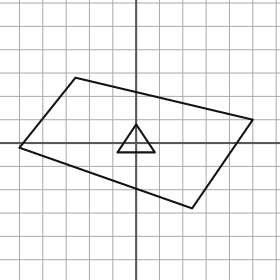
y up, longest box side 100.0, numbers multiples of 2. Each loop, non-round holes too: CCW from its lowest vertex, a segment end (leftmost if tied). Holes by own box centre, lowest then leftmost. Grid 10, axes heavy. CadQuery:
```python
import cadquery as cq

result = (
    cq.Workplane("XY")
    .moveTo(24.0, -28.0)
    .lineTo(50.0, 10.0)
    .lineTo(-26.0, 28.0)
    .lineTo(-50.0, -2.0)
    .close()
    .moveTo(-8.0, -4.0)
    .lineTo(8.0, -4.0)
    .lineTo(0.0, 8.0)
    .close()
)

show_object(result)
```